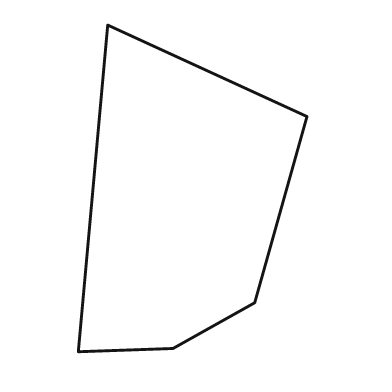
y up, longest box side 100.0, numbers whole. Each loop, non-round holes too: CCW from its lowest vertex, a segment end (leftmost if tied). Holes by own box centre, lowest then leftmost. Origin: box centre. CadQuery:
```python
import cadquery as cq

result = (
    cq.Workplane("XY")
    .moveTo(-35.0, -50.0)
    .lineTo(-6.0, -49.0)
    .lineTo(19.0, -35.0)
    .lineTo(35.0, 22.0)
    .lineTo(-26.0, 50.0)
    .close()
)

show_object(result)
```